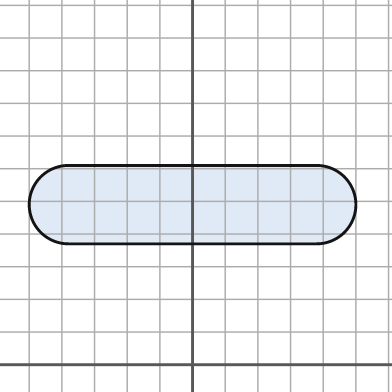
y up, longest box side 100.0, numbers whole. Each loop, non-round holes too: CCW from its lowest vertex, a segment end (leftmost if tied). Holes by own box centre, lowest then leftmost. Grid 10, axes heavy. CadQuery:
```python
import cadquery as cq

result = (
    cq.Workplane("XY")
    .moveTo(-38.0, 37.0)
    .lineTo(38.0, 37.0)
    .threePointArc((50.0, 49.0), (38.0, 61.0))
    .lineTo(-38.0, 61.0)
    .threePointArc((-50.0, 49.0), (-38.0, 37.0))
    .close()
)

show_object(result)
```